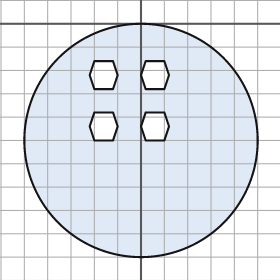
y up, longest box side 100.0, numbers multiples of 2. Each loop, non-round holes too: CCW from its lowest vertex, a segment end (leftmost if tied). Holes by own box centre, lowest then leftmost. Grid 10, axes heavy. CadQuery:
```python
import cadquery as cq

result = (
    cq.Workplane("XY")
    .moveTo(0.0, -50.0)
    .circle(50.0)
    .moveTo(-20.0, -50.0)
    .lineTo(-12.0, -50.0)
    .lineTo(-10.0, -44.0)
    .lineTo(-12.0, -38.0)
    .lineTo(-20.0, -38.0)
    .lineTo(-22.0, -44.0)
    .close()
    .moveTo(2.0, -50.0)
    .lineTo(10.0, -50.0)
    .lineTo(12.0, -44.0)
    .lineTo(10.0, -38.0)
    .lineTo(2.0, -38.0)
    .lineTo(0.0, -44.0)
    .close()
    .moveTo(-20.0, -28.0)
    .lineTo(-12.0, -28.0)
    .lineTo(-10.0, -22.0)
    .lineTo(-12.0, -16.0)
    .lineTo(-20.0, -16.0)
    .lineTo(-22.0, -22.0)
    .close()
    .moveTo(2.0, -28.0)
    .lineTo(10.0, -28.0)
    .lineTo(12.0, -22.0)
    .lineTo(10.0, -16.0)
    .lineTo(2.0, -16.0)
    .lineTo(0.0, -22.0)
    .close()
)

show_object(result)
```